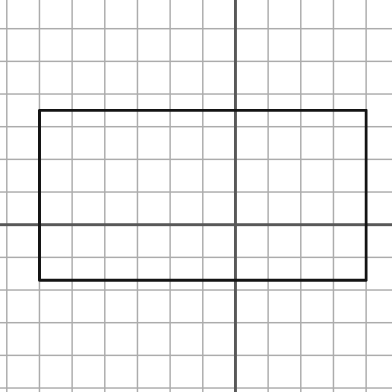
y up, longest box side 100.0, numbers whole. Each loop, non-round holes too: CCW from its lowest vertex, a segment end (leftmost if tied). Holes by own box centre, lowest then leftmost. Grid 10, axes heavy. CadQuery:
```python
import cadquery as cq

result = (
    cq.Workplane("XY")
    .moveTo(-60.0, -17.0)
    .lineTo(40.0, -17.0)
    .lineTo(40.0, 35.0)
    .lineTo(-60.0, 35.0)
    .close()
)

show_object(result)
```